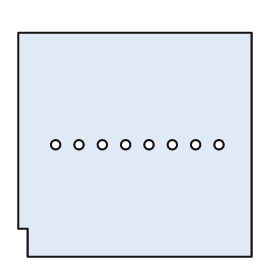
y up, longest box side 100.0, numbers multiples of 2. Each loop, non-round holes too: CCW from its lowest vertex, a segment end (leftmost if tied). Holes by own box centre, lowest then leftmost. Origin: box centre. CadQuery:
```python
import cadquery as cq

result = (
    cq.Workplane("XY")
    .moveTo(-46.0, -48.0)
    .lineTo(50.0, -48.0)
    .lineTo(50.0, 48.0)
    .lineTo(-50.0, 48.0)
    .lineTo(-50.0, -36.0)
    .lineTo(-46.0, -36.0)
    .close()
    .moveTo(-34.0, 0.0)
    .circle(2.0)
    .moveTo(-24.0, 0.0)
    .circle(2.0)
    .moveTo(-14.0, 0.0)
    .circle(2.0)
    .moveTo(-4.0, 0.0)
    .circle(2.0)
    .moveTo(6.0, 0.0)
    .circle(2.0)
    .moveTo(16.0, 0.0)
    .circle(2.0)
    .moveTo(26.0, 0.0)
    .circle(2.0)
    .moveTo(36.0, 0.0)
    .circle(2.0)
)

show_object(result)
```